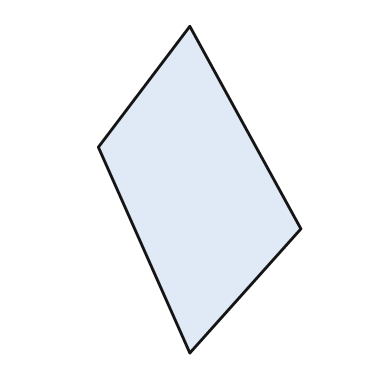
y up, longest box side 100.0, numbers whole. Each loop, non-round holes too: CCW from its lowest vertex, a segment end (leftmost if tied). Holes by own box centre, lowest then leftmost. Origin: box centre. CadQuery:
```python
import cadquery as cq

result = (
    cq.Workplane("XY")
    .moveTo(-3.0, -50.0)
    .lineTo(31.0, -12.0)
    .lineTo(-3.0, 50.0)
    .lineTo(-31.0, 13.0)
    .close()
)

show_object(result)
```